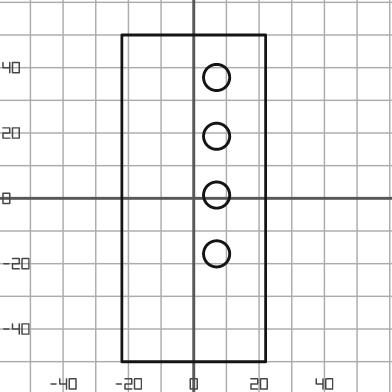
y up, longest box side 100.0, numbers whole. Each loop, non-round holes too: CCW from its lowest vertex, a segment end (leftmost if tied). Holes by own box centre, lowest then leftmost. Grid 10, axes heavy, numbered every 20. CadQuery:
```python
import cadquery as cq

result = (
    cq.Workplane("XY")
    .moveTo(-22.0, -50.0)
    .lineTo(22.0, -50.0)
    .lineTo(22.0, 50.0)
    .lineTo(-22.0, 50.0)
    .close()
    .moveTo(7.0, -17.0)
    .circle(4.0)
    .moveTo(7.0, 1.0)
    .circle(4.0)
    .moveTo(7.0, 19.0)
    .circle(4.0)
    .moveTo(7.0, 37.0)
    .circle(4.0)
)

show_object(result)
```